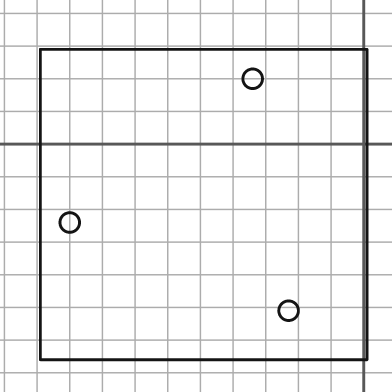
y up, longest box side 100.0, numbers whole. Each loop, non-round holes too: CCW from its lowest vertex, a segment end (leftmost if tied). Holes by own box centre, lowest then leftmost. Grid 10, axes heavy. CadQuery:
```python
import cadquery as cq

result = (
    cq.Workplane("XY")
    .moveTo(-99.0, -66.0)
    .lineTo(1.0, -66.0)
    .lineTo(1.0, 29.0)
    .lineTo(-99.0, 29.0)
    .close()
    .moveTo(-23.0, -51.0)
    .circle(3.0)
    .moveTo(-90.0, -24.0)
    .circle(3.0)
    .moveTo(-34.0, 20.0)
    .circle(3.0)
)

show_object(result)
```